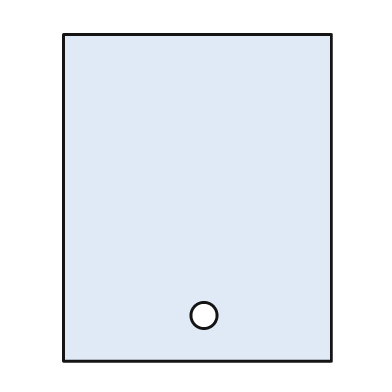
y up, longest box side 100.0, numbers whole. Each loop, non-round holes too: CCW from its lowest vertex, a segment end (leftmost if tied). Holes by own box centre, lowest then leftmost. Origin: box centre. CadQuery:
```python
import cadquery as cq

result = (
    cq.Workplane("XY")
    .moveTo(-41.0, -50.0)
    .lineTo(41.0, -50.0)
    .lineTo(41.0, 50.0)
    .lineTo(-41.0, 50.0)
    .close()
    .moveTo(2.0, -36.0)
    .circle(4.0)
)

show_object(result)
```